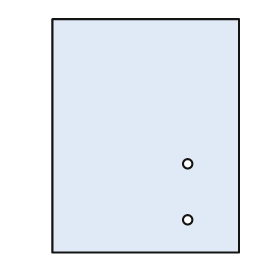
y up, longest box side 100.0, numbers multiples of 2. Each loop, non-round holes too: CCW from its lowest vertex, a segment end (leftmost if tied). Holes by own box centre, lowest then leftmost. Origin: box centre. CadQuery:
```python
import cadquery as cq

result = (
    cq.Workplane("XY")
    .moveTo(-40.0, -50.0)
    .lineTo(40.0, -50.0)
    .lineTo(40.0, 50.0)
    .lineTo(-40.0, 50.0)
    .close()
    .moveTo(18.0, -36.0)
    .circle(2.0)
    .moveTo(18.0, -12.0)
    .circle(2.0)
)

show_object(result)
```